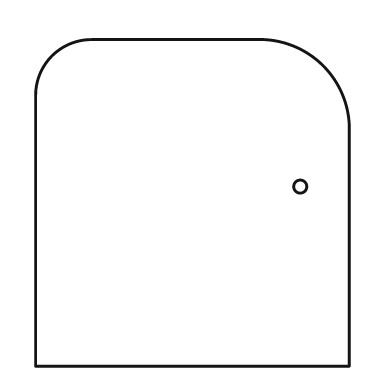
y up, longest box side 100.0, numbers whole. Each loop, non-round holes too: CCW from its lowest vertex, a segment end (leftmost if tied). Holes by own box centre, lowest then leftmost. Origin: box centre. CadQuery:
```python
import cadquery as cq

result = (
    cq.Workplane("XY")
    .moveTo(-48.0, -50.0)
    .lineTo(48.0, -50.0)
    .lineTo(48.0, 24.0)
    .threePointArc((40.0, 42.0), (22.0, 50.0))
    .lineTo(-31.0, 50.0)
    .threePointArc((-43.0, 45.0), (-48.0, 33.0))
    .close()
    .moveTo(33.0, 5.0)
    .circle(2.0)
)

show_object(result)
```